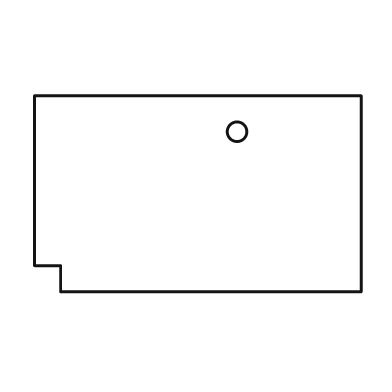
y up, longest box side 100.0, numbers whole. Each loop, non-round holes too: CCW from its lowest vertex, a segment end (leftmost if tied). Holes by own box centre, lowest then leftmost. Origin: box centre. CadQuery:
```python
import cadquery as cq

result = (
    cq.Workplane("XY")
    .moveTo(-42.0, -30.0)
    .lineTo(50.0, -30.0)
    .lineTo(50.0, 30.0)
    .lineTo(-50.0, 30.0)
    .lineTo(-50.0, -22.0)
    .lineTo(-42.0, -22.0)
    .close()
    .moveTo(12.0, 19.0)
    .circle(3.0)
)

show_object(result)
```